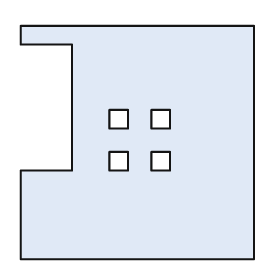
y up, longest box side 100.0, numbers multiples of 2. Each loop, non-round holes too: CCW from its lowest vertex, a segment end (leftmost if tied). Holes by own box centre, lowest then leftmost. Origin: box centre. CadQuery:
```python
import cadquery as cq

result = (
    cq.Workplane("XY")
    .moveTo(-50.0, -50.0)
    .lineTo(50.0, -50.0)
    .lineTo(50.0, 50.0)
    .lineTo(-50.0, 50.0)
    .lineTo(-50.0, 42.0)
    .lineTo(-28.0, 42.0)
    .lineTo(-28.0, -12.0)
    .lineTo(-50.0, -12.0)
    .close()
    .moveTo(-12.0, -12.0)
    .lineTo(-4.0, -12.0)
    .lineTo(-4.0, -4.0)
    .lineTo(-12.0, -4.0)
    .close()
    .moveTo(6.0, -12.0)
    .lineTo(14.0, -12.0)
    .lineTo(14.0, -4.0)
    .lineTo(6.0, -4.0)
    .close()
    .moveTo(-12.0, 6.0)
    .lineTo(-4.0, 6.0)
    .lineTo(-4.0, 14.0)
    .lineTo(-12.0, 14.0)
    .close()
    .moveTo(6.0, 6.0)
    .lineTo(14.0, 6.0)
    .lineTo(14.0, 14.0)
    .lineTo(6.0, 14.0)
    .close()
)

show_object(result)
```